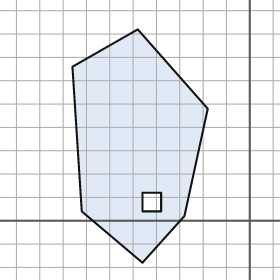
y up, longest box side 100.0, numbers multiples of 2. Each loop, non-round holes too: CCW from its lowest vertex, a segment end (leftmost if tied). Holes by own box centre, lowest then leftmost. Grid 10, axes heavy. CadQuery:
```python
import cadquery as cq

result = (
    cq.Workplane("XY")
    .moveTo(-46.0, -18.0)
    .lineTo(-28.0, 2.0)
    .lineTo(-18.0, 48.0)
    .lineTo(-48.0, 82.0)
    .lineTo(-76.0, 66.0)
    .lineTo(-72.0, 4.0)
    .close()
    .moveTo(-46.0, 4.0)
    .lineTo(-38.0, 4.0)
    .lineTo(-38.0, 12.0)
    .lineTo(-46.0, 12.0)
    .close()
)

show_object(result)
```